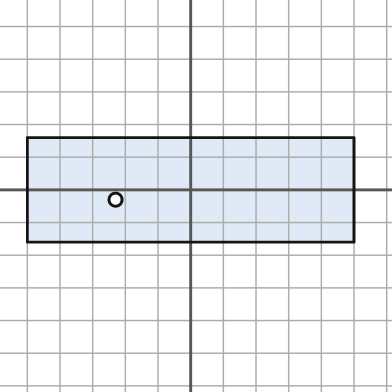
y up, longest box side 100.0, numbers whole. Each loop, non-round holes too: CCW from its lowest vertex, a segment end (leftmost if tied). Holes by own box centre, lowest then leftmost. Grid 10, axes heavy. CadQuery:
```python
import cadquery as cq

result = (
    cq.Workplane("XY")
    .moveTo(-50.0, -16.0)
    .lineTo(50.0, -16.0)
    .lineTo(50.0, 16.0)
    .lineTo(-50.0, 16.0)
    .close()
    .moveTo(-23.0, -3.0)
    .circle(2.0)
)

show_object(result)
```